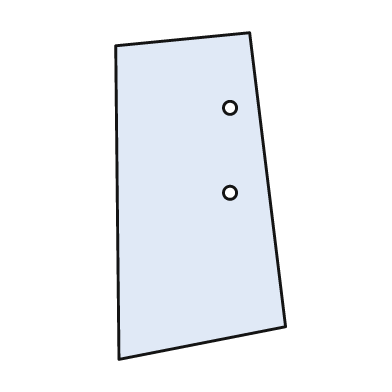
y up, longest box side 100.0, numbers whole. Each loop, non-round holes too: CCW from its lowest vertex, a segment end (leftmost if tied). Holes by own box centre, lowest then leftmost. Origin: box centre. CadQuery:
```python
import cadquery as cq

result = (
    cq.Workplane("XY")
    .moveTo(-25.0, -50.0)
    .lineTo(26.0, -40.0)
    .lineTo(15.0, 50.0)
    .lineTo(-26.0, 46.0)
    .close()
    .moveTo(9.0, 1.0)
    .circle(2.0)
    .moveTo(9.0, 27.0)
    .circle(2.0)
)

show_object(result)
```